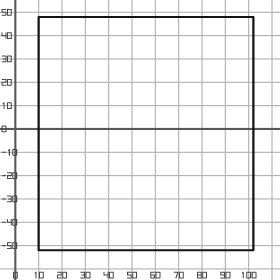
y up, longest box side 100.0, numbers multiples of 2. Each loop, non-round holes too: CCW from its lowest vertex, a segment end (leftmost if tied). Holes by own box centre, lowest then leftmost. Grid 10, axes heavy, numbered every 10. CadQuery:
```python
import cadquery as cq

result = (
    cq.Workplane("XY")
    .moveTo(10.0, -52.0)
    .lineTo(102.0, -52.0)
    .lineTo(102.0, 48.0)
    .lineTo(10.0, 48.0)
    .close()
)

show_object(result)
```